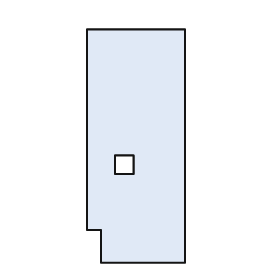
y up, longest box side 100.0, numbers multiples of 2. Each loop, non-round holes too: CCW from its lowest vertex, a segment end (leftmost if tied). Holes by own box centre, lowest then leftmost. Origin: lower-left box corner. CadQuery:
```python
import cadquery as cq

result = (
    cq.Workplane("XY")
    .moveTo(6.0, 0.0)
    .lineTo(42.0, 0.0)
    .lineTo(42.0, 100.0)
    .lineTo(0.0, 100.0)
    .lineTo(0.0, 14.0)
    .lineTo(6.0, 14.0)
    .close()
    .moveTo(12.0, 38.0)
    .lineTo(20.0, 38.0)
    .lineTo(20.0, 46.0)
    .lineTo(12.0, 46.0)
    .close()
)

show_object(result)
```